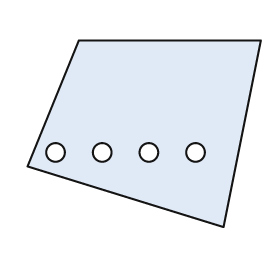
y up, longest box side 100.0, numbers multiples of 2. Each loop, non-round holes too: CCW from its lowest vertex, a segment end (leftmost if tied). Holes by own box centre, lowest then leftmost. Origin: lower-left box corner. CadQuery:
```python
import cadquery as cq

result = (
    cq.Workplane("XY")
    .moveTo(84.0, 0.0)
    .lineTo(100.0, 80.0)
    .lineTo(22.0, 80.0)
    .lineTo(0.0, 26.0)
    .close()
    .moveTo(12.0, 32.0)
    .circle(4.0)
    .moveTo(32.0, 32.0)
    .circle(4.0)
    .moveTo(52.0, 32.0)
    .circle(4.0)
    .moveTo(72.0, 32.0)
    .circle(4.0)
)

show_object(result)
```